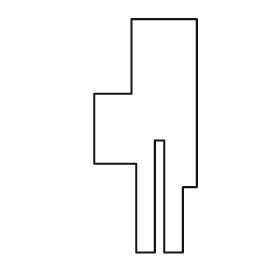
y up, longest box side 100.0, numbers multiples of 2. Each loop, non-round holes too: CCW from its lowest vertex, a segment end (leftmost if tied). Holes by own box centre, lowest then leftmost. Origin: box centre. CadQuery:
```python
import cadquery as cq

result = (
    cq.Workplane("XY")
    .moveTo(-4.0, -50.0)
    .lineTo(4.0, -50.0)
    .lineTo(4.0, -2.0)
    .lineTo(8.0, -2.0)
    .lineTo(8.0, -50.0)
    .lineTo(16.0, -50.0)
    .lineTo(16.0, -22.0)
    .lineTo(22.0, -22.0)
    .lineTo(22.0, 50.0)
    .lineTo(-6.0, 50.0)
    .lineTo(-6.0, 18.0)
    .lineTo(-22.0, 18.0)
    .lineTo(-22.0, -12.0)
    .lineTo(-4.0, -12.0)
    .close()
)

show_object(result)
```